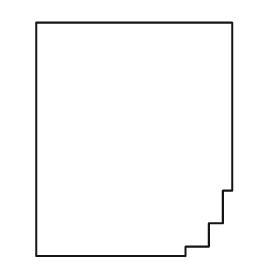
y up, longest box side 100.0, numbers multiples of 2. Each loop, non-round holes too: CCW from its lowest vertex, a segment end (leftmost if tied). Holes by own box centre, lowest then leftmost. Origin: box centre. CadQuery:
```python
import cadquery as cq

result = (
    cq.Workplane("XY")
    .moveTo(-42.0, -50.0)
    .lineTo(22.0, -50.0)
    .lineTo(22.0, -46.0)
    .lineTo(32.0, -46.0)
    .lineTo(32.0, -36.0)
    .lineTo(38.0, -36.0)
    .lineTo(38.0, -22.0)
    .lineTo(42.0, -22.0)
    .lineTo(42.0, 50.0)
    .lineTo(-42.0, 50.0)
    .close()
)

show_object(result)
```